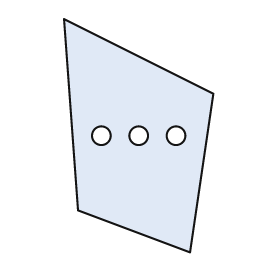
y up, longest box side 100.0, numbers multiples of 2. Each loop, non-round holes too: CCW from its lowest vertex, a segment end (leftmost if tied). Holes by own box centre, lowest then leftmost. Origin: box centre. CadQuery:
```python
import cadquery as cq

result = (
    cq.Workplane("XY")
    .moveTo(22.0, -50.0)
    .lineTo(32.0, 18.0)
    .lineTo(-32.0, 50.0)
    .lineTo(-26.0, -32.0)
    .close()
    .moveTo(-16.0, 0.0)
    .circle(4.0)
    .moveTo(0.0, 0.0)
    .circle(4.0)
    .moveTo(16.0, 0.0)
    .circle(4.0)
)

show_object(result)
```